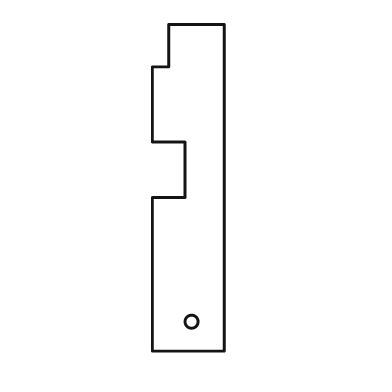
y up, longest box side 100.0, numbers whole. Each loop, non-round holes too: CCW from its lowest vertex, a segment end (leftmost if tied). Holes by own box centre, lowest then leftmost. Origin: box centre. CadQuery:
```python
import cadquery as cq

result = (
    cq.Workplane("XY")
    .moveTo(-11.0, -50.0)
    .lineTo(11.0, -50.0)
    .lineTo(11.0, 50.0)
    .lineTo(-6.0, 50.0)
    .lineTo(-6.0, 37.0)
    .lineTo(-11.0, 37.0)
    .lineTo(-11.0, 14.0)
    .lineTo(-1.0, 14.0)
    .lineTo(-1.0, -3.0)
    .lineTo(-11.0, -3.0)
    .close()
    .moveTo(1.0, -41.0)
    .circle(2.0)
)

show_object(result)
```